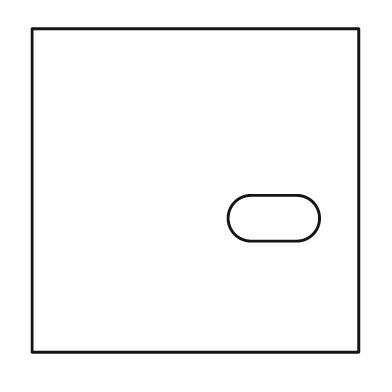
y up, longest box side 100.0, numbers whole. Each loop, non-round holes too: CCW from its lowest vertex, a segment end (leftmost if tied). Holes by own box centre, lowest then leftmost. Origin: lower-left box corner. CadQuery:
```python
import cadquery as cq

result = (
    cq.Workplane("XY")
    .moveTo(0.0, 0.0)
    .lineTo(100.0, 0.0)
    .lineTo(100.0, 99.0)
    .lineTo(0.0, 99.0)
    .close()
    .moveTo(67.0, 34.0)
    .lineTo(81.0, 34.0)
    .threePointArc((88.0, 41.0), (81.0, 48.0))
    .lineTo(67.0, 48.0)
    .threePointArc((60.0, 41.0), (67.0, 34.0))
    .close()
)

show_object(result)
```